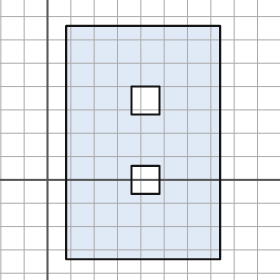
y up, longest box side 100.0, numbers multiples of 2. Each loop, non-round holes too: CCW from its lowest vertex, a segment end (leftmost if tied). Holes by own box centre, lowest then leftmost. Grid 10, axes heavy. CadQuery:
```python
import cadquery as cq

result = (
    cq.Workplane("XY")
    .moveTo(8.0, -34.0)
    .lineTo(74.0, -34.0)
    .lineTo(74.0, 66.0)
    .lineTo(8.0, 66.0)
    .close()
    .moveTo(36.0, -6.0)
    .lineTo(48.0, -6.0)
    .lineTo(48.0, 6.0)
    .lineTo(36.0, 6.0)
    .close()
    .moveTo(36.0, 28.0)
    .lineTo(48.0, 28.0)
    .lineTo(48.0, 40.0)
    .lineTo(36.0, 40.0)
    .close()
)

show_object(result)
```